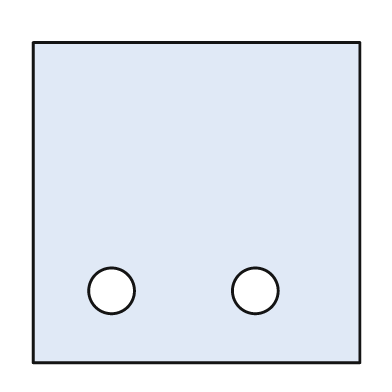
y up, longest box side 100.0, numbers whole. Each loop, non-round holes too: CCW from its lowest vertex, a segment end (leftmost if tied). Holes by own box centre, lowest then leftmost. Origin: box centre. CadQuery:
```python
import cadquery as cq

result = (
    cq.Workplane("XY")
    .moveTo(-50.0, -49.0)
    .lineTo(50.0, -49.0)
    .lineTo(50.0, 49.0)
    .lineTo(-50.0, 49.0)
    .close()
    .moveTo(-26.0, -27.0)
    .circle(7.0)
    .moveTo(18.0, -27.0)
    .circle(7.0)
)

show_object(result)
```